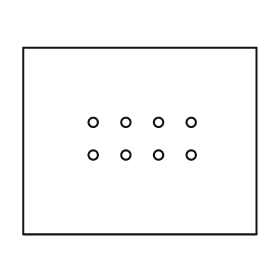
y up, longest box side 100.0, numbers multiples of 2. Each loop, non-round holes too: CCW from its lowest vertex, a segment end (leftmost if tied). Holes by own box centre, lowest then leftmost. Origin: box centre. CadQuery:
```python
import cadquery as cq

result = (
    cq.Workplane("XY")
    .moveTo(-50.0, -40.0)
    .lineTo(50.0, -40.0)
    .lineTo(50.0, 40.0)
    .lineTo(-50.0, 40.0)
    .close()
    .moveTo(-20.0, -6.0)
    .circle(2.0)
    .moveTo(-6.0, -6.0)
    .circle(2.0)
    .moveTo(8.0, -6.0)
    .circle(2.0)
    .moveTo(22.0, -6.0)
    .circle(2.0)
    .moveTo(-20.0, 8.0)
    .circle(2.0)
    .moveTo(-6.0, 8.0)
    .circle(2.0)
    .moveTo(8.0, 8.0)
    .circle(2.0)
    .moveTo(22.0, 8.0)
    .circle(2.0)
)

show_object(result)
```